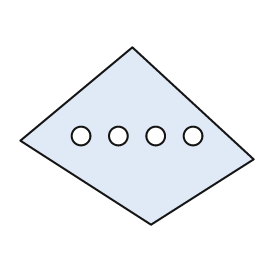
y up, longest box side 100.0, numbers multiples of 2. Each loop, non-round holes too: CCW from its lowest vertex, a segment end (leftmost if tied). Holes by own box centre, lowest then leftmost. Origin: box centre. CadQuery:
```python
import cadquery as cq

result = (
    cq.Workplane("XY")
    .moveTo(6.0, -38.0)
    .lineTo(50.0, -10.0)
    .lineTo(-2.0, 38.0)
    .lineTo(-50.0, -2.0)
    .close()
    .moveTo(-24.0, 0.0)
    .circle(4.0)
    .moveTo(-8.0, 0.0)
    .circle(4.0)
    .moveTo(8.0, 0.0)
    .circle(4.0)
    .moveTo(24.0, 0.0)
    .circle(4.0)
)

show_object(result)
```